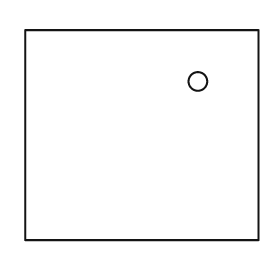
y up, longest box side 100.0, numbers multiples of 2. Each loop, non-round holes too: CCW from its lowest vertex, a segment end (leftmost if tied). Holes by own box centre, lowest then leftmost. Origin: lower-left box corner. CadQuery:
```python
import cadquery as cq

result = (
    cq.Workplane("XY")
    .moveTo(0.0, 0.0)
    .lineTo(100.0, 0.0)
    .lineTo(100.0, 90.0)
    .lineTo(0.0, 90.0)
    .close()
    .moveTo(74.0, 68.0)
    .circle(4.0)
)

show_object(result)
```